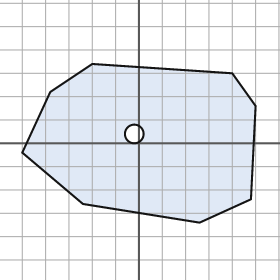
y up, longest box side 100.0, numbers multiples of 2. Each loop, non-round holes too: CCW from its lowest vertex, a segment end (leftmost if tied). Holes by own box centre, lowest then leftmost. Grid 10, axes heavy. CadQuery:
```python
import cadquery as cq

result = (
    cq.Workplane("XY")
    .moveTo(26.0, -34.0)
    .lineTo(48.0, -24.0)
    .lineTo(50.0, 16.0)
    .lineTo(40.0, 30.0)
    .lineTo(-20.0, 34.0)
    .lineTo(-38.0, 22.0)
    .lineTo(-50.0, -4.0)
    .lineTo(-24.0, -26.0)
    .close()
    .moveTo(-2.0, 4.0)
    .circle(4.0)
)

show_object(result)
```